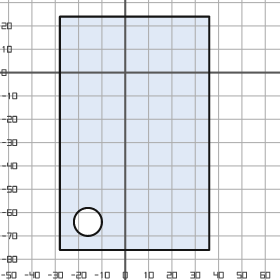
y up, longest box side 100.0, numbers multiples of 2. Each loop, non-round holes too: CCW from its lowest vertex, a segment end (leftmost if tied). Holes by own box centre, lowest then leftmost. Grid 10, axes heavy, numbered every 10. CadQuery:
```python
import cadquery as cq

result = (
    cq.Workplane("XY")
    .moveTo(-28.0, -76.0)
    .lineTo(36.0, -76.0)
    .lineTo(36.0, 24.0)
    .lineTo(-28.0, 24.0)
    .close()
    .moveTo(-16.0, -64.0)
    .circle(6.0)
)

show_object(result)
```